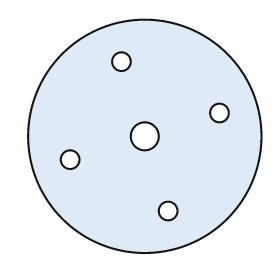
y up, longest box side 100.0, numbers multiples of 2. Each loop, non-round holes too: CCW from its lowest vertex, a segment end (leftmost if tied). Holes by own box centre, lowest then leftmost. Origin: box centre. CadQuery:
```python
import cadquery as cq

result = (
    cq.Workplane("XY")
    .moveTo(0.0, 0.0)
    .circle(50.0)
    .moveTo(10.0, -32.0)
    .circle(4.0)
    .moveTo(-32.0, -10.0)
    .circle(4.0)
    .moveTo(0.0, 0.0)
    .circle(6.0)
    .moveTo(32.0, 10.0)
    .circle(4.0)
    .moveTo(-10.0, 32.0)
    .circle(4.0)
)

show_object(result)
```